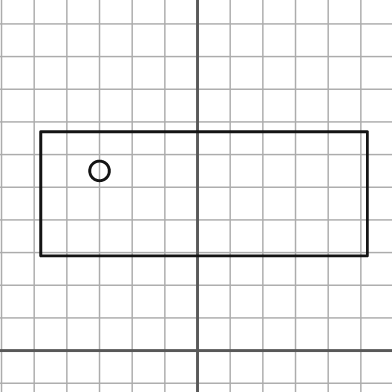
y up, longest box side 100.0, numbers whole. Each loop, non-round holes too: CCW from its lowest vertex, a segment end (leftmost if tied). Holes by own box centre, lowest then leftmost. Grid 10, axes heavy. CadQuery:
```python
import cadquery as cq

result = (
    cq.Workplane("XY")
    .moveTo(-48.0, 29.0)
    .lineTo(52.0, 29.0)
    .lineTo(52.0, 67.0)
    .lineTo(-48.0, 67.0)
    .close()
    .moveTo(-30.0, 55.0)
    .circle(3.0)
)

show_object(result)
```